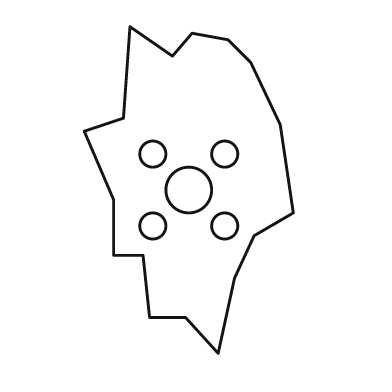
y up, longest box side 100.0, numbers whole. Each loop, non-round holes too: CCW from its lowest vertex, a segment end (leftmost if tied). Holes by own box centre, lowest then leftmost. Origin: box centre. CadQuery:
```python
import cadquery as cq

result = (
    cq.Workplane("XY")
    .moveTo(9.0, -50.0)
    .lineTo(14.0, -27.0)
    .lineTo(20.0, -14.0)
    .lineTo(32.0, -7.0)
    .lineTo(28.0, 20.0)
    .lineTo(19.0, 39.0)
    .lineTo(12.0, 46.0)
    .lineTo(1.0, 48.0)
    .lineTo(-5.0, 41.0)
    .lineTo(-18.0, 50.0)
    .lineTo(-20.0, 22.0)
    .lineTo(-32.0, 18.0)
    .lineTo(-23.0, -3.0)
    .lineTo(-23.0, -20.0)
    .lineTo(-14.0, -20.0)
    .lineTo(-12.0, -39.0)
    .lineTo(-1.0, -39.0)
    .close()
    .moveTo(-11.0, -11.0)
    .circle(4.0)
    .moveTo(11.0, -11.0)
    .circle(4.0)
    .moveTo(0.0, 0.0)
    .circle(7.0)
    .moveTo(-11.0, 11.0)
    .circle(4.0)
    .moveTo(11.0, 11.0)
    .circle(4.0)
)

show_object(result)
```